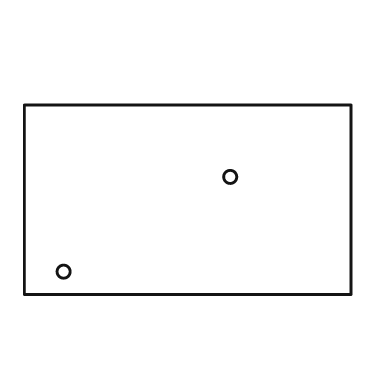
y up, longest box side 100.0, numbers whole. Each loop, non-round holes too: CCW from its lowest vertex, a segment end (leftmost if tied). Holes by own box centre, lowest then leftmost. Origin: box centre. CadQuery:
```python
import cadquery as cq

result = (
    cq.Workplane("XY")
    .moveTo(-50.0, -29.0)
    .lineTo(50.0, -29.0)
    .lineTo(50.0, 29.0)
    .lineTo(-50.0, 29.0)
    .close()
    .moveTo(-38.0, -22.0)
    .circle(2.0)
    .moveTo(13.0, 7.0)
    .circle(2.0)
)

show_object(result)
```